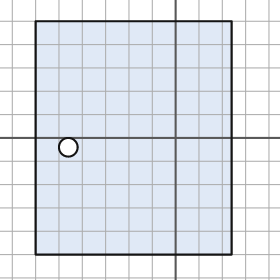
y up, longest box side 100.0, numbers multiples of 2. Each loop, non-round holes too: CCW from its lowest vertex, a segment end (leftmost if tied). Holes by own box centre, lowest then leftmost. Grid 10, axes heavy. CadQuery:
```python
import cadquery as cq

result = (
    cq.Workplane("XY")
    .moveTo(-60.0, -50.0)
    .lineTo(24.0, -50.0)
    .lineTo(24.0, 50.0)
    .lineTo(-60.0, 50.0)
    .close()
    .moveTo(-46.0, -4.0)
    .circle(4.0)
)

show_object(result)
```